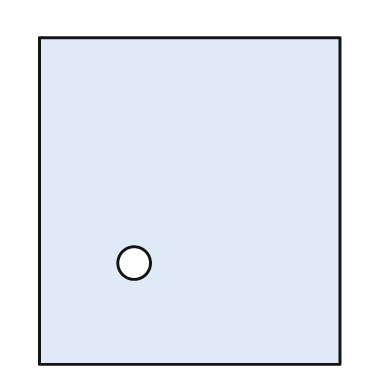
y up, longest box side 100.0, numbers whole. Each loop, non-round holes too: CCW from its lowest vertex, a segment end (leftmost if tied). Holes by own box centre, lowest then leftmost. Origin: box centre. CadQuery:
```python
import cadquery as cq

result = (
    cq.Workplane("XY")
    .moveTo(-46.0, -50.0)
    .lineTo(46.0, -50.0)
    .lineTo(46.0, 50.0)
    .lineTo(-46.0, 50.0)
    .close()
    .moveTo(-17.0, -19.0)
    .circle(5.0)
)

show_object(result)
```